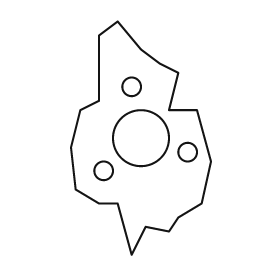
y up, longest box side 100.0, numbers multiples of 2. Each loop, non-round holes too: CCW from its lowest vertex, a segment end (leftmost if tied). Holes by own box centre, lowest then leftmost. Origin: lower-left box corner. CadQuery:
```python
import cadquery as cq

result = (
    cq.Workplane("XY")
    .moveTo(26.0, 0.0)
    .lineTo(32.0, 12.0)
    .lineTo(42.0, 10.0)
    .lineTo(46.0, 16.0)
    .lineTo(56.0, 22.0)
    .lineTo(60.0, 40.0)
    .lineTo(54.0, 62.0)
    .lineTo(42.0, 62.0)
    .lineTo(46.0, 78.0)
    .lineTo(38.0, 82.0)
    .lineTo(30.0, 88.0)
    .lineTo(20.0, 100.0)
    .lineTo(12.0, 94.0)
    .lineTo(12.0, 66.0)
    .lineTo(4.0, 62.0)
    .lineTo(0.0, 46.0)
    .lineTo(2.0, 28.0)
    .lineTo(12.0, 22.0)
    .lineTo(20.0, 22.0)
    .close()
    .moveTo(14.0, 36.0)
    .circle(4.0)
    .moveTo(50.0, 44.0)
    .circle(4.0)
    .moveTo(30.0, 50.0)
    .circle(12.0)
    .moveTo(26.0, 72.0)
    .circle(4.0)
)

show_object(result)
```